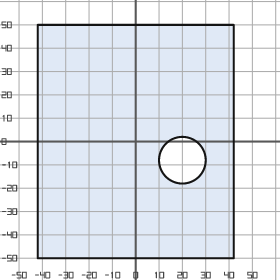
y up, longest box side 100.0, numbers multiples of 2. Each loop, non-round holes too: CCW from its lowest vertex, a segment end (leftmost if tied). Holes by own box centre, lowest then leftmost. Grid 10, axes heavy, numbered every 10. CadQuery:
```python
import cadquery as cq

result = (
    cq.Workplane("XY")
    .moveTo(-42.0, -50.0)
    .lineTo(42.0, -50.0)
    .lineTo(42.0, 50.0)
    .lineTo(-42.0, 50.0)
    .close()
    .moveTo(20.0, -8.0)
    .circle(10.0)
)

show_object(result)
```